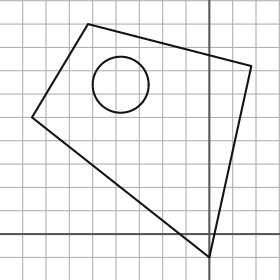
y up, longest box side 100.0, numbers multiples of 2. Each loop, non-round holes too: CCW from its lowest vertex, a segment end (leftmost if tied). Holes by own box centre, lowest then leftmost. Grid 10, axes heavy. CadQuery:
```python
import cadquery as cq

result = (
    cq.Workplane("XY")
    .moveTo(0.0, -10.0)
    .lineTo(18.0, 72.0)
    .lineTo(-52.0, 90.0)
    .lineTo(-76.0, 50.0)
    .close()
    .moveTo(-38.0, 64.0)
    .circle(12.0)
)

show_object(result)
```